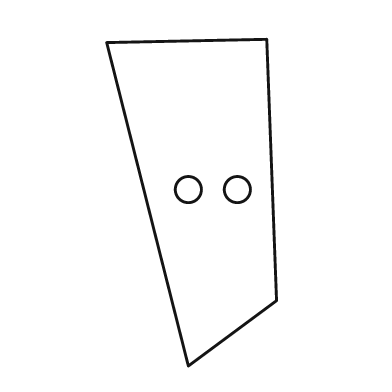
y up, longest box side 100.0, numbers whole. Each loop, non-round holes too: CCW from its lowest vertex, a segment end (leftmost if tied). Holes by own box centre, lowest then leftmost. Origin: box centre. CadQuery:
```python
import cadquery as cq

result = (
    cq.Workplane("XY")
    .moveTo(-1.0, -50.0)
    .lineTo(26.0, -30.0)
    .lineTo(23.0, 50.0)
    .lineTo(-26.0, 49.0)
    .close()
    .moveTo(-1.0, 4.0)
    .circle(4.0)
    .moveTo(14.0, 4.0)
    .circle(4.0)
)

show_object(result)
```